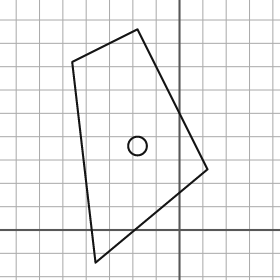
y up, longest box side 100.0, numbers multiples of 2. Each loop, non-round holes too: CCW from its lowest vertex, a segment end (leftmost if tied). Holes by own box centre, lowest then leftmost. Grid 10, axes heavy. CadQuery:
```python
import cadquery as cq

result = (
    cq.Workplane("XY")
    .moveTo(-36.0, -14.0)
    .lineTo(12.0, 26.0)
    .lineTo(-18.0, 86.0)
    .lineTo(-46.0, 72.0)
    .close()
    .moveTo(-18.0, 36.0)
    .circle(4.0)
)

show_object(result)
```